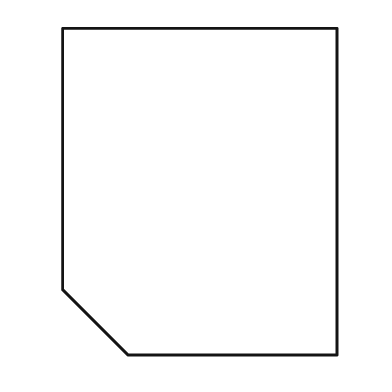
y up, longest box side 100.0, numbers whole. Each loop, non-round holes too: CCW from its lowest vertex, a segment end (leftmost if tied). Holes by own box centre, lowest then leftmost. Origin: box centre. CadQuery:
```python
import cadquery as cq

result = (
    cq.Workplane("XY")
    .moveTo(-22.0, -50.0)
    .lineTo(42.0, -50.0)
    .lineTo(42.0, 50.0)
    .lineTo(-42.0, 50.0)
    .lineTo(-42.0, -30.0)
    .close()
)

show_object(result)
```